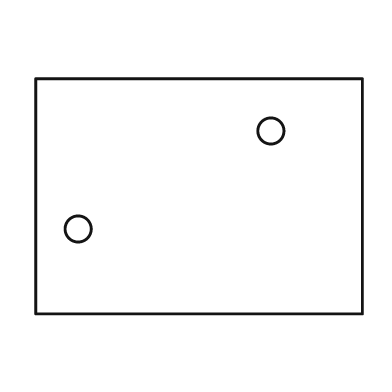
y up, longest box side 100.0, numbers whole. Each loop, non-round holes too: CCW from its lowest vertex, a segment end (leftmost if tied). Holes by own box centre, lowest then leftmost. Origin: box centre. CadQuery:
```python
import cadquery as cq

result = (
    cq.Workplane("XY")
    .moveTo(-50.0, -36.0)
    .lineTo(50.0, -36.0)
    .lineTo(50.0, 36.0)
    .lineTo(-50.0, 36.0)
    .close()
    .moveTo(-37.0, -10.0)
    .circle(4.0)
    .moveTo(22.0, 20.0)
    .circle(4.0)
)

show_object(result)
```